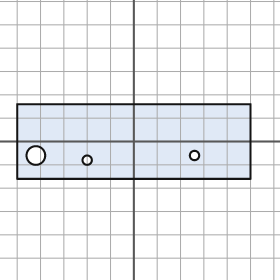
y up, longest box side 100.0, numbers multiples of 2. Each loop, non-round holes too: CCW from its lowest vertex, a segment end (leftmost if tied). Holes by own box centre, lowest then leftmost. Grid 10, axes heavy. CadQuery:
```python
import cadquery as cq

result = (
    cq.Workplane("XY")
    .moveTo(-50.0, -16.0)
    .lineTo(50.0, -16.0)
    .lineTo(50.0, 16.0)
    .lineTo(-50.0, 16.0)
    .close()
    .moveTo(-20.0, -8.0)
    .circle(2.0)
    .moveTo(-42.0, -6.0)
    .circle(4.0)
    .moveTo(26.0, -6.0)
    .circle(2.0)
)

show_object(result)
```